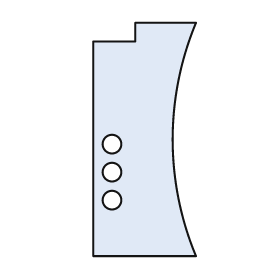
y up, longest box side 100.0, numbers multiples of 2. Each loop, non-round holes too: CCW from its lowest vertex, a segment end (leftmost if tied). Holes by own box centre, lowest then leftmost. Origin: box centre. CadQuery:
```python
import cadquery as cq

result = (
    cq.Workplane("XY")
    .moveTo(-22.0, -50.0)
    .lineTo(22.0, -50.0)
    .threePointArc((12.0, 0.0), (22.0, 50.0))
    .lineTo(-4.0, 50.0)
    .lineTo(-4.0, 42.0)
    .lineTo(-22.0, 42.0)
    .close()
    .moveTo(-14.0, -26.0)
    .circle(4.0)
    .moveTo(-14.0, -14.0)
    .circle(4.0)
    .moveTo(-14.0, -2.0)
    .circle(4.0)
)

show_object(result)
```